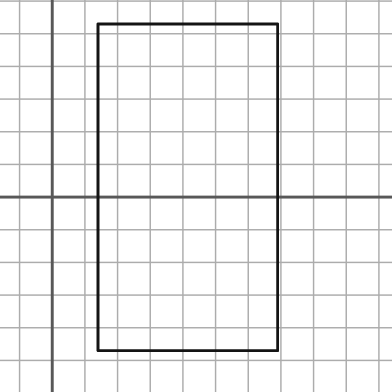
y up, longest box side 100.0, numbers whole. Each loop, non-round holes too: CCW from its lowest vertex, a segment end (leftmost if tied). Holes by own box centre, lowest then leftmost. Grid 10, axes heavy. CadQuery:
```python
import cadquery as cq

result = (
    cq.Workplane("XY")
    .moveTo(14.0, -47.0)
    .lineTo(69.0, -47.0)
    .lineTo(69.0, 53.0)
    .lineTo(14.0, 53.0)
    .close()
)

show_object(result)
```